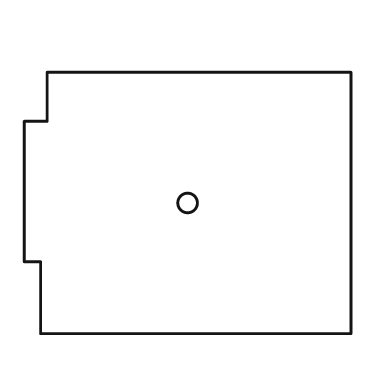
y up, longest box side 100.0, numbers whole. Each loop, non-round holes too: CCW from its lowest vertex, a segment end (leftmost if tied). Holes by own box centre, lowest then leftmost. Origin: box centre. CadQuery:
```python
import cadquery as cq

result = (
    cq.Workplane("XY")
    .moveTo(-45.0, -40.0)
    .lineTo(50.0, -40.0)
    .lineTo(50.0, 40.0)
    .lineTo(-43.0, 40.0)
    .lineTo(-43.0, 25.0)
    .lineTo(-50.0, 25.0)
    .lineTo(-50.0, -18.0)
    .lineTo(-45.0, -18.0)
    .close()
    .moveTo(0.0, 0.0)
    .circle(3.0)
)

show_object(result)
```